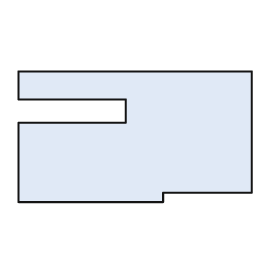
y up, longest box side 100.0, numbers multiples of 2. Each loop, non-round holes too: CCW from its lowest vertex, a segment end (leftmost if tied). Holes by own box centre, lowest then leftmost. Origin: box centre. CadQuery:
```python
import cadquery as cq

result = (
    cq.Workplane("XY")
    .moveTo(-50.0, -28.0)
    .lineTo(12.0, -28.0)
    .lineTo(12.0, -24.0)
    .lineTo(50.0, -24.0)
    .lineTo(50.0, 28.0)
    .lineTo(-50.0, 28.0)
    .lineTo(-50.0, 16.0)
    .lineTo(-4.0, 16.0)
    .lineTo(-4.0, 6.0)
    .lineTo(-50.0, 6.0)
    .close()
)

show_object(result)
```